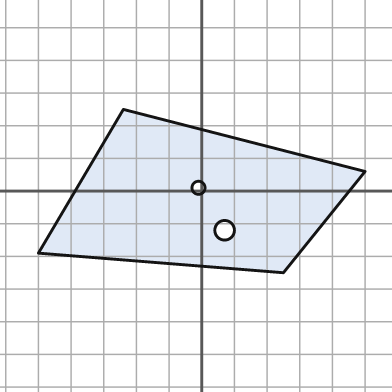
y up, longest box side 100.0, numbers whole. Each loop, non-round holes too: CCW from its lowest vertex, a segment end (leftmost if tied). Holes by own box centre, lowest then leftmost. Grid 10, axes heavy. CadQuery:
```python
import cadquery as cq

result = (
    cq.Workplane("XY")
    .moveTo(25.0, -25.0)
    .lineTo(50.0, 6.0)
    .lineTo(-24.0, 25.0)
    .lineTo(-50.0, -19.0)
    .close()
    .moveTo(7.0, -12.0)
    .circle(3.0)
    .moveTo(-1.0, 1.0)
    .circle(2.0)
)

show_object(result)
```